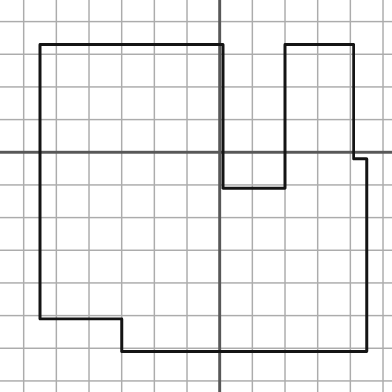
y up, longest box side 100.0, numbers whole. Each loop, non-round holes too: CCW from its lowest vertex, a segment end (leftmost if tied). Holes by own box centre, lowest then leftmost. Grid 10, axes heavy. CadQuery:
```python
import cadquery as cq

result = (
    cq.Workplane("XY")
    .moveTo(-30.0, -61.0)
    .lineTo(45.0, -61.0)
    .lineTo(45.0, -2.0)
    .lineTo(41.0, -2.0)
    .lineTo(41.0, 33.0)
    .lineTo(20.0, 33.0)
    .lineTo(20.0, -11.0)
    .lineTo(1.0, -11.0)
    .lineTo(1.0, 33.0)
    .lineTo(-55.0, 33.0)
    .lineTo(-55.0, -51.0)
    .lineTo(-30.0, -51.0)
    .close()
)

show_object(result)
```